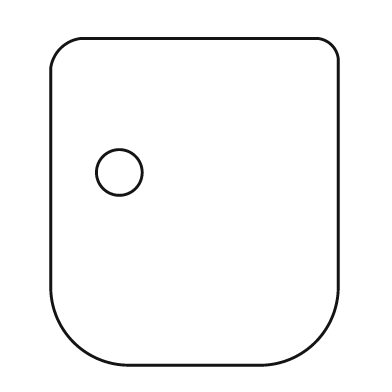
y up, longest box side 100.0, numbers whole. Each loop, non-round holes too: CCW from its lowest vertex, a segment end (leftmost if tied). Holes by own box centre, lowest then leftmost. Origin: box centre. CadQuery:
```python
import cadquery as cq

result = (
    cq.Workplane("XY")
    .moveTo(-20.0, -50.0)
    .lineTo(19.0, -50.0)
    .threePointArc((37.0, -43.0), (44.0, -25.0))
    .lineTo(44.0, 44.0)
    .threePointArc((42.0, 48.0), (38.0, 50.0))
    .lineTo(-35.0, 50.0)
    .threePointArc((-41.0, 47.0), (-44.0, 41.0))
    .lineTo(-44.0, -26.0)
    .threePointArc((-37.0, -43.0), (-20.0, -50.0))
    .close()
    .moveTo(-23.0, 9.0)
    .circle(7.0)
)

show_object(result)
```